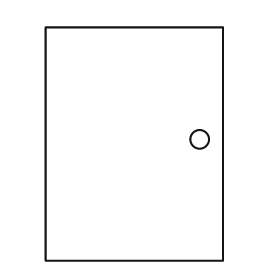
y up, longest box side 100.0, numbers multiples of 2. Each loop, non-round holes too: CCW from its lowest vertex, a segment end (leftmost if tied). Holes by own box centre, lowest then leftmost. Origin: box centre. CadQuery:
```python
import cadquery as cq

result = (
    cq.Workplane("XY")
    .moveTo(-38.0, -50.0)
    .lineTo(38.0, -50.0)
    .lineTo(38.0, 50.0)
    .lineTo(-38.0, 50.0)
    .close()
    .moveTo(28.0, 2.0)
    .circle(4.0)
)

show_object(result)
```